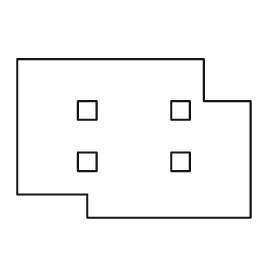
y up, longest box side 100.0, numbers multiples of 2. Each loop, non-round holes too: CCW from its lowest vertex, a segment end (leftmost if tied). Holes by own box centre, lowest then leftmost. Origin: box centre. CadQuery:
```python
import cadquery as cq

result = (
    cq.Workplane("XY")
    .moveTo(-20.0, -34.0)
    .lineTo(50.0, -34.0)
    .lineTo(50.0, 16.0)
    .lineTo(30.0, 16.0)
    .lineTo(30.0, 34.0)
    .lineTo(-50.0, 34.0)
    .lineTo(-50.0, -24.0)
    .lineTo(-20.0, -24.0)
    .close()
    .moveTo(-24.0, -14.0)
    .lineTo(-16.0, -14.0)
    .lineTo(-16.0, -6.0)
    .lineTo(-24.0, -6.0)
    .close()
    .moveTo(16.0, -14.0)
    .lineTo(24.0, -14.0)
    .lineTo(24.0, -6.0)
    .lineTo(16.0, -6.0)
    .close()
    .moveTo(-24.0, 8.0)
    .lineTo(-16.0, 8.0)
    .lineTo(-16.0, 16.0)
    .lineTo(-24.0, 16.0)
    .close()
    .moveTo(16.0, 8.0)
    .lineTo(24.0, 8.0)
    .lineTo(24.0, 16.0)
    .lineTo(16.0, 16.0)
    .close()
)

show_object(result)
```